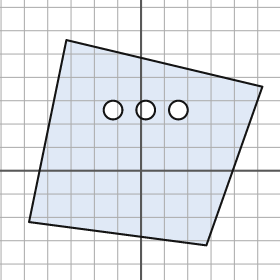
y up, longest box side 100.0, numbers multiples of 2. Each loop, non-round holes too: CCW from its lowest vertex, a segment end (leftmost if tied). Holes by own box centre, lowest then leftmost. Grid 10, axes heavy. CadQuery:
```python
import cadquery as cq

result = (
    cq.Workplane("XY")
    .moveTo(28.0, -32.0)
    .lineTo(52.0, 36.0)
    .lineTo(-32.0, 56.0)
    .lineTo(-48.0, -22.0)
    .close()
    .moveTo(-12.0, 26.0)
    .circle(4.0)
    .moveTo(2.0, 26.0)
    .circle(4.0)
    .moveTo(16.0, 26.0)
    .circle(4.0)
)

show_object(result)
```